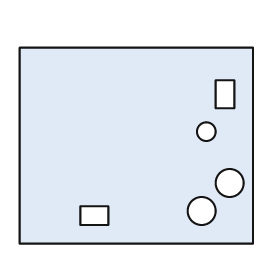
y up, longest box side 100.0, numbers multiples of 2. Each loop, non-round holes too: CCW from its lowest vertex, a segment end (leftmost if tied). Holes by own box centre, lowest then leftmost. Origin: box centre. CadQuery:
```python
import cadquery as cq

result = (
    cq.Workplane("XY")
    .moveTo(-50.0, -42.0)
    .lineTo(50.0, -42.0)
    .lineTo(50.0, 42.0)
    .lineTo(-50.0, 42.0)
    .close()
    .moveTo(-24.0, -34.0)
    .lineTo(-12.0, -34.0)
    .lineTo(-12.0, -26.0)
    .lineTo(-24.0, -26.0)
    .close()
    .moveTo(28.0, -28.0)
    .circle(6.0)
    .moveTo(40.0, -16.0)
    .circle(6.0)
    .moveTo(30.0, 6.0)
    .circle(4.0)
    .moveTo(34.0, 16.0)
    .lineTo(42.0, 16.0)
    .lineTo(42.0, 28.0)
    .lineTo(34.0, 28.0)
    .close()
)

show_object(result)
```